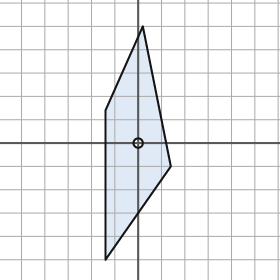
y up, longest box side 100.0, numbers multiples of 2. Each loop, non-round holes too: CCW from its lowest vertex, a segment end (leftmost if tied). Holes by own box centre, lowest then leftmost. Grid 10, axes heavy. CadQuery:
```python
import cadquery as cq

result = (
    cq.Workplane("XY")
    .moveTo(-14.0, -50.0)
    .lineTo(14.0, -10.0)
    .lineTo(2.0, 50.0)
    .lineTo(-14.0, 14.0)
    .close()
    .moveTo(0.0, 0.0)
    .circle(2.0)
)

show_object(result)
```